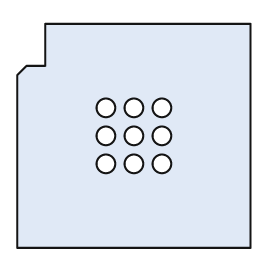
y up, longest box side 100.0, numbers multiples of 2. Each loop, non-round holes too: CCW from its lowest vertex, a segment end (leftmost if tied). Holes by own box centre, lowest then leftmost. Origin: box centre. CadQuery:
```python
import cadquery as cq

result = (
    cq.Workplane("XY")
    .moveTo(-50.0, -48.0)
    .lineTo(50.0, -48.0)
    .lineTo(50.0, 48.0)
    .lineTo(-38.0, 48.0)
    .lineTo(-38.0, 30.0)
    .lineTo(-46.0, 30.0)
    .lineTo(-50.0, 26.0)
    .close()
    .moveTo(-12.0, -12.0)
    .circle(4.0)
    .moveTo(0.0, -12.0)
    .circle(4.0)
    .moveTo(12.0, -12.0)
    .circle(4.0)
    .moveTo(-12.0, 0.0)
    .circle(4.0)
    .moveTo(0.0, 0.0)
    .circle(4.0)
    .moveTo(12.0, 0.0)
    .circle(4.0)
    .moveTo(-12.0, 12.0)
    .circle(4.0)
    .moveTo(0.0, 12.0)
    .circle(4.0)
    .moveTo(12.0, 12.0)
    .circle(4.0)
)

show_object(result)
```